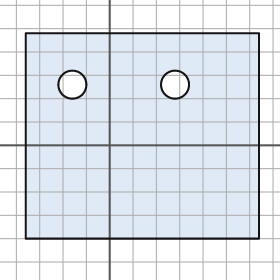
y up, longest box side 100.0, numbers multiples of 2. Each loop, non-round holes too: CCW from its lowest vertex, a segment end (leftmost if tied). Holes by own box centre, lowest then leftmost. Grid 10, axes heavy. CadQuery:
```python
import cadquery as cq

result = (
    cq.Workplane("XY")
    .moveTo(-36.0, -40.0)
    .lineTo(64.0, -40.0)
    .lineTo(64.0, 48.0)
    .lineTo(-36.0, 48.0)
    .close()
    .moveTo(-16.0, 26.0)
    .circle(6.0)
    .moveTo(28.0, 26.0)
    .circle(6.0)
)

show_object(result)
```